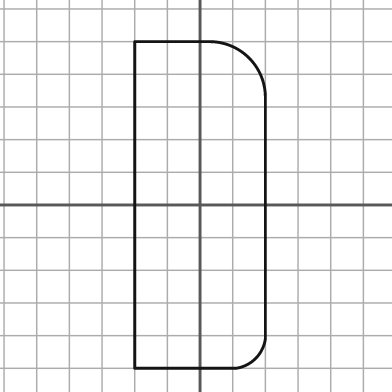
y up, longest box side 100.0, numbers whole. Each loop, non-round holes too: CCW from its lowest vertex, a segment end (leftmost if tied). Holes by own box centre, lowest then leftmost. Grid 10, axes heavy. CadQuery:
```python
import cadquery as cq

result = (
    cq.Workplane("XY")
    .moveTo(-20.0, -50.0)
    .lineTo(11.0, -50.0)
    .threePointArc((17.0, -47.0), (20.0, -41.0))
    .lineTo(20.0, 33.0)
    .threePointArc((15.0, 45.0), (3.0, 50.0))
    .lineTo(-20.0, 50.0)
    .close()
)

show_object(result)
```